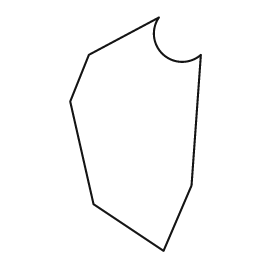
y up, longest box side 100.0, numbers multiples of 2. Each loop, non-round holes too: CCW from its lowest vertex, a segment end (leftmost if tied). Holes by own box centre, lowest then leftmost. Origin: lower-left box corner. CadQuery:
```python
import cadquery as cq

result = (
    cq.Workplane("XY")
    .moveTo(40.0, 0.0)
    .lineTo(52.0, 28.0)
    .lineTo(56.0, 84.0)
    .threePointArc((40.0, 84.0), (38.0, 100.0))
    .lineTo(8.0, 84.0)
    .lineTo(0.0, 64.0)
    .lineTo(10.0, 20.0)
    .close()
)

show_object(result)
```